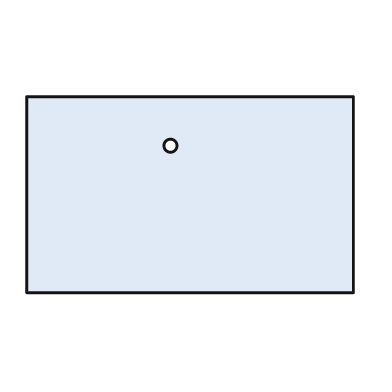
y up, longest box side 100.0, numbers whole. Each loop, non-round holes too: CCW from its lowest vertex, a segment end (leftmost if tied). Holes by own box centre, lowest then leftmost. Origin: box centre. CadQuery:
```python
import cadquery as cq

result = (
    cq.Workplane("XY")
    .moveTo(-50.0, -30.0)
    .lineTo(50.0, -30.0)
    .lineTo(50.0, 30.0)
    .lineTo(-50.0, 30.0)
    .close()
    .moveTo(-6.0, 15.0)
    .circle(2.0)
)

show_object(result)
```